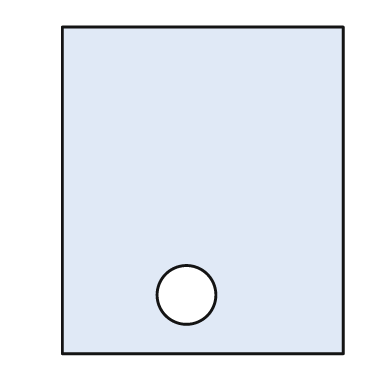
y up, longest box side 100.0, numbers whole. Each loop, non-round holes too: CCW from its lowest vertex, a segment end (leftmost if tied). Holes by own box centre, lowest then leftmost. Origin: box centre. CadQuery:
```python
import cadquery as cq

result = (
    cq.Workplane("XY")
    .moveTo(-43.0, -50.0)
    .lineTo(43.0, -50.0)
    .lineTo(43.0, 50.0)
    .lineTo(-43.0, 50.0)
    .close()
    .moveTo(-5.0, -32.0)
    .circle(9.0)
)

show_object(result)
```